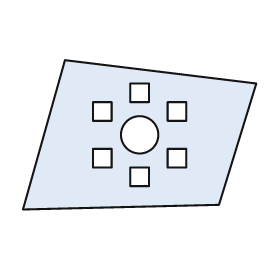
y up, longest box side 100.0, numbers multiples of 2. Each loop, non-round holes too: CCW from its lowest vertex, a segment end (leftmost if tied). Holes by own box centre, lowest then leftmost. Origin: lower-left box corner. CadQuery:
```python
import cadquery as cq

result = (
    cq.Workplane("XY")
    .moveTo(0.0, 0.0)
    .lineTo(84.0, 2.0)
    .lineTo(100.0, 54.0)
    .lineTo(18.0, 64.0)
    .close()
    .moveTo(46.0, 10.0)
    .lineTo(54.0, 10.0)
    .lineTo(54.0, 18.0)
    .lineTo(46.0, 18.0)
    .close()
    .moveTo(30.0, 18.0)
    .lineTo(38.0, 18.0)
    .lineTo(38.0, 26.0)
    .lineTo(30.0, 26.0)
    .close()
    .moveTo(62.0, 18.0)
    .lineTo(70.0, 18.0)
    .lineTo(70.0, 26.0)
    .lineTo(62.0, 26.0)
    .close()
    .moveTo(50.0, 32.0)
    .circle(8.0)
    .moveTo(30.0, 38.0)
    .lineTo(38.0, 38.0)
    .lineTo(38.0, 46.0)
    .lineTo(30.0, 46.0)
    .close()
    .moveTo(62.0, 38.0)
    .lineTo(70.0, 38.0)
    .lineTo(70.0, 46.0)
    .lineTo(62.0, 46.0)
    .close()
    .moveTo(46.0, 46.0)
    .lineTo(54.0, 46.0)
    .lineTo(54.0, 54.0)
    .lineTo(46.0, 54.0)
    .close()
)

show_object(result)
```